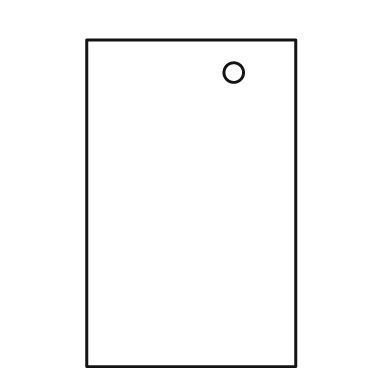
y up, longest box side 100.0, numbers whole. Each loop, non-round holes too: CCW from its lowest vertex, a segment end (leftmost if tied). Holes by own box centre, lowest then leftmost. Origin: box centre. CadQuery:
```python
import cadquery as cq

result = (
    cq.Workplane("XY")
    .moveTo(-32.0, -50.0)
    .lineTo(32.0, -50.0)
    .lineTo(32.0, 50.0)
    .lineTo(-32.0, 50.0)
    .close()
    .moveTo(13.0, 40.0)
    .circle(3.0)
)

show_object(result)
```